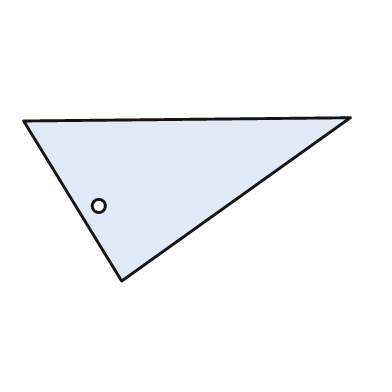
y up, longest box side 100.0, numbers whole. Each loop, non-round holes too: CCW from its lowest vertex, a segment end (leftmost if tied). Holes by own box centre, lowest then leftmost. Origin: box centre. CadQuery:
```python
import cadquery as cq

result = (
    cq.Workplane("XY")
    .moveTo(-20.0, -25.0)
    .lineTo(50.0, 25.0)
    .lineTo(-50.0, 24.0)
    .close()
    .moveTo(-27.0, -2.0)
    .circle(2.0)
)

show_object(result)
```